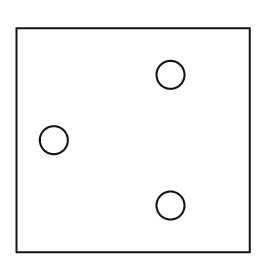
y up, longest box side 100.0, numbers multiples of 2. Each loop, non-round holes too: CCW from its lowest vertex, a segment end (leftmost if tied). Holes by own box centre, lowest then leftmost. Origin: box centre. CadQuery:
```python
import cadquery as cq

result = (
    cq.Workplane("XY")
    .moveTo(-50.0, -48.0)
    .lineTo(50.0, -48.0)
    .lineTo(50.0, 48.0)
    .lineTo(-50.0, 48.0)
    .close()
    .moveTo(16.0, -28.0)
    .circle(6.0)
    .moveTo(-34.0, 0.0)
    .circle(6.0)
    .moveTo(16.0, 28.0)
    .circle(6.0)
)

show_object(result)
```